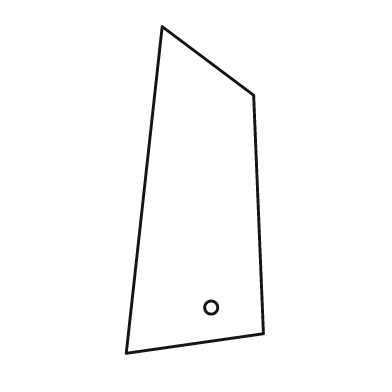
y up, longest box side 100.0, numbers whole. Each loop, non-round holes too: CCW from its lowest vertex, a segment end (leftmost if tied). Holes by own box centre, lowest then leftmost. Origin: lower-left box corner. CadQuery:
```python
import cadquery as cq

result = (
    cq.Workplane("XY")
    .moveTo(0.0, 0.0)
    .lineTo(42.0, 6.0)
    .lineTo(39.0, 79.0)
    .lineTo(11.0, 100.0)
    .close()
    .moveTo(26.0, 14.0)
    .circle(2.0)
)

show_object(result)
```